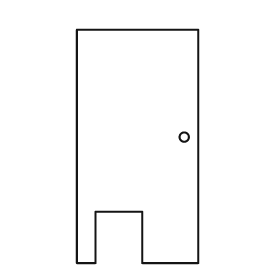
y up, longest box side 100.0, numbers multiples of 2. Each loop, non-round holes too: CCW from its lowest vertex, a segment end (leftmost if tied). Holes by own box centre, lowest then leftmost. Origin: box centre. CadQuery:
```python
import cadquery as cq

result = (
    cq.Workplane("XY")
    .moveTo(-26.0, -50.0)
    .lineTo(-18.0, -50.0)
    .lineTo(-18.0, -28.0)
    .lineTo(2.0, -28.0)
    .lineTo(2.0, -50.0)
    .lineTo(26.0, -50.0)
    .lineTo(26.0, 50.0)
    .lineTo(-26.0, 50.0)
    .close()
    .moveTo(20.0, 4.0)
    .circle(2.0)
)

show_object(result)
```